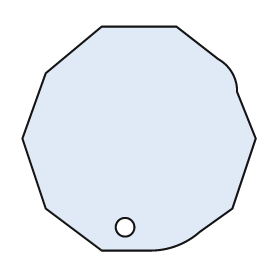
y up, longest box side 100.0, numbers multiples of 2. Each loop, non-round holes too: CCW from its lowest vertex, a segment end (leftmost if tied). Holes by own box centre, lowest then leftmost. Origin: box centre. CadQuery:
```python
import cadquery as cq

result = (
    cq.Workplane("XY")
    .moveTo(-16.0, -48.0)
    .lineTo(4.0, -48.0)
    .threePointArc((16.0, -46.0), (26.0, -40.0))
    .lineTo(40.0, -30.0)
    .lineTo(50.0, 0.0)
    .lineTo(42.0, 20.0)
    .threePointArc((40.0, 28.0), (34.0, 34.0))
    .lineTo(16.0, 48.0)
    .lineTo(-16.0, 48.0)
    .lineTo(-40.0, 28.0)
    .lineTo(-50.0, 0.0)
    .lineTo(-40.0, -30.0)
    .close()
    .moveTo(-6.0, -38.0)
    .circle(4.0)
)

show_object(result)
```